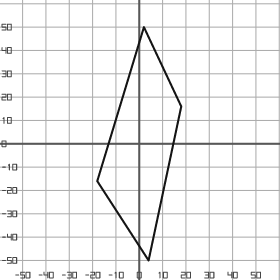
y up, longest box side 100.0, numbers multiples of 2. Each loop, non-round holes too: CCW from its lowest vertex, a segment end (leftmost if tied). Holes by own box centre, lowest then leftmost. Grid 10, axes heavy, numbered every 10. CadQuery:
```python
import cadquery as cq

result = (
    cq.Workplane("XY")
    .moveTo(4.0, -50.0)
    .lineTo(18.0, 16.0)
    .lineTo(2.0, 50.0)
    .lineTo(-18.0, -16.0)
    .close()
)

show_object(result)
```